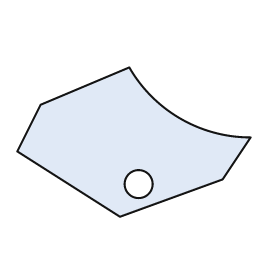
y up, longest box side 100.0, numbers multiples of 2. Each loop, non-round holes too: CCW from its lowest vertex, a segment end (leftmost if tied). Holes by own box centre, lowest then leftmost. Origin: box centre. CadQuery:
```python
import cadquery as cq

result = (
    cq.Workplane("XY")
    .moveTo(-6.0, -32.0)
    .lineTo(38.0, -16.0)
    .lineTo(50.0, 2.0)
    .threePointArc((20.0, 10.0), (-2.0, 32.0))
    .lineTo(-40.0, 16.0)
    .lineTo(-50.0, -4.0)
    .close()
    .moveTo(2.0, -18.0)
    .circle(6.0)
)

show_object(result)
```